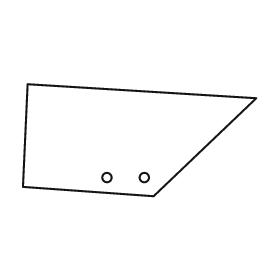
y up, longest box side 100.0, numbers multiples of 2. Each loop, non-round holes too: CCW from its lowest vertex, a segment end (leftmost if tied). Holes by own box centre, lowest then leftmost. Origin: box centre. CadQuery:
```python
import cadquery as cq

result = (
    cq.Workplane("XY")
    .moveTo(6.0, -24.0)
    .lineTo(50.0, 18.0)
    .lineTo(-48.0, 24.0)
    .lineTo(-50.0, -20.0)
    .close()
    .moveTo(-14.0, -16.0)
    .circle(2.0)
    .moveTo(2.0, -16.0)
    .circle(2.0)
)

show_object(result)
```